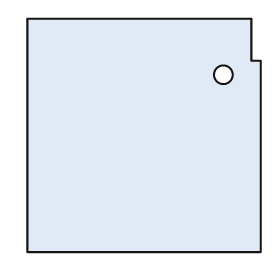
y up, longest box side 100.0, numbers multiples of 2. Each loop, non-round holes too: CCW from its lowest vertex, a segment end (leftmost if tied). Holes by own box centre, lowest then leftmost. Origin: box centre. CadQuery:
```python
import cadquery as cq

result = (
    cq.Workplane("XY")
    .moveTo(-50.0, -50.0)
    .lineTo(50.0, -50.0)
    .lineTo(50.0, 32.0)
    .lineTo(46.0, 32.0)
    .lineTo(46.0, 50.0)
    .lineTo(-50.0, 50.0)
    .close()
    .moveTo(34.0, 26.0)
    .circle(4.0)
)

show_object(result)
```